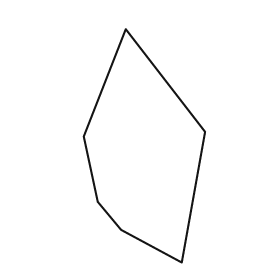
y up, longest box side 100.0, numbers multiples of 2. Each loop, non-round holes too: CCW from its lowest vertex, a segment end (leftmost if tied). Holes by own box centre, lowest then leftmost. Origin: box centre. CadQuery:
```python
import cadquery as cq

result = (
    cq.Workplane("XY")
    .moveTo(16.0, -50.0)
    .lineTo(26.0, 6.0)
    .lineTo(-8.0, 50.0)
    .lineTo(-26.0, 4.0)
    .lineTo(-20.0, -24.0)
    .lineTo(-10.0, -36.0)
    .close()
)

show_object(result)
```